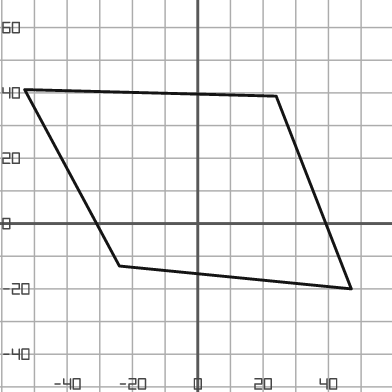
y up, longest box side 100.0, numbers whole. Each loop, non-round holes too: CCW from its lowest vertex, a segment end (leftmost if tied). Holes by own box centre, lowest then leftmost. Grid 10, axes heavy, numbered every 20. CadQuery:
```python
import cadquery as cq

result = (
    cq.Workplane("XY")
    .moveTo(47.0, -20.0)
    .lineTo(24.0, 39.0)
    .lineTo(-53.0, 41.0)
    .lineTo(-24.0, -13.0)
    .close()
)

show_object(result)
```